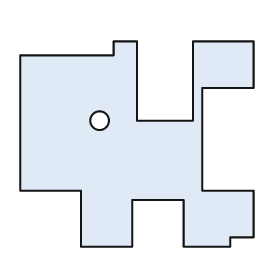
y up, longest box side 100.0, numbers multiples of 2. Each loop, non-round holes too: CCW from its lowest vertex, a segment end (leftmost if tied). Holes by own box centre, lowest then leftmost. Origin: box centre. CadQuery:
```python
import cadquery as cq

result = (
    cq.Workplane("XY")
    .moveTo(-24.0, -44.0)
    .lineTo(-2.0, -44.0)
    .lineTo(-2.0, -24.0)
    .lineTo(20.0, -24.0)
    .lineTo(20.0, -44.0)
    .lineTo(40.0, -44.0)
    .lineTo(40.0, -40.0)
    .lineTo(50.0, -40.0)
    .lineTo(50.0, -20.0)
    .lineTo(28.0, -20.0)
    .lineTo(28.0, 24.0)
    .lineTo(50.0, 24.0)
    .lineTo(50.0, 44.0)
    .lineTo(24.0, 44.0)
    .lineTo(24.0, 10.0)
    .lineTo(0.0, 10.0)
    .lineTo(0.0, 44.0)
    .lineTo(-10.0, 44.0)
    .lineTo(-10.0, 38.0)
    .lineTo(-50.0, 38.0)
    .lineTo(-50.0, -20.0)
    .lineTo(-24.0, -20.0)
    .close()
    .moveTo(-16.0, 10.0)
    .circle(4.0)
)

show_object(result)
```